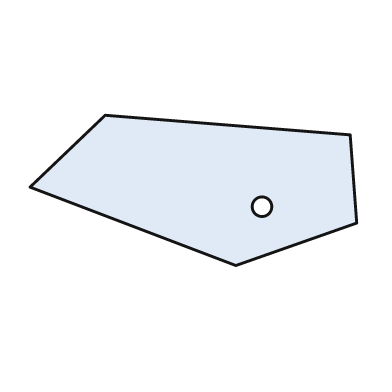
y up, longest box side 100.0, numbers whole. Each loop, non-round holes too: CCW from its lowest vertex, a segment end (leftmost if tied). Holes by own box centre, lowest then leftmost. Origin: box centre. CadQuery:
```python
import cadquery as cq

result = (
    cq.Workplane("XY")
    .moveTo(13.0, -23.0)
    .lineTo(50.0, -10.0)
    .lineTo(48.0, 17.0)
    .lineTo(-27.0, 23.0)
    .lineTo(-50.0, 1.0)
    .close()
    .moveTo(21.0, -5.0)
    .circle(3.0)
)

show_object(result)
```